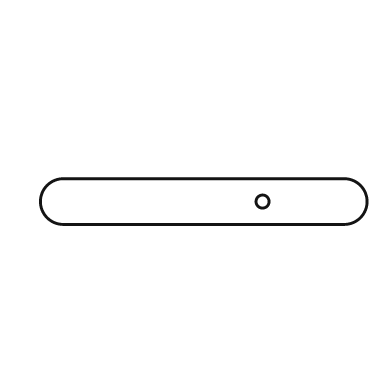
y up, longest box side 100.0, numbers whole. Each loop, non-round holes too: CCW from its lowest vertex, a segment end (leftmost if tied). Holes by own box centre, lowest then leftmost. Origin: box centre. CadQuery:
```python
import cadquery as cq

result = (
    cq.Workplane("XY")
    .moveTo(-43.0, -7.0)
    .lineTo(43.0, -7.0)
    .threePointArc((50.0, 0.0), (43.0, 7.0))
    .lineTo(-43.0, 7.0)
    .threePointArc((-50.0, 0.0), (-43.0, -7.0))
    .close()
    .moveTo(18.0, 0.0)
    .circle(2.0)
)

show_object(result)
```